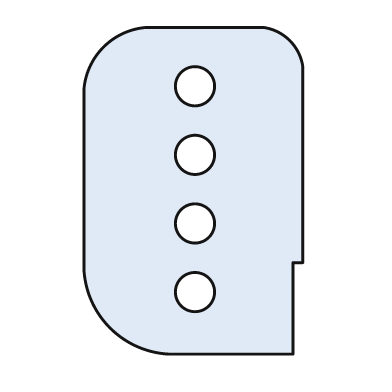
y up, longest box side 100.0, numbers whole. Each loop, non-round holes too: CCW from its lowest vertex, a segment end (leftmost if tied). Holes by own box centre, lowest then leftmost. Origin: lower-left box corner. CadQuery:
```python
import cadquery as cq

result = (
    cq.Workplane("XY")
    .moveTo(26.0, 0.0)
    .lineTo(64.0, 0.0)
    .lineTo(64.0, 28.0)
    .lineTo(67.0, 28.0)
    .lineTo(67.0, 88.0)
    .threePointArc((63.0, 96.0), (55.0, 100.0))
    .lineTo(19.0, 100.0)
    .threePointArc((6.0, 94.0), (0.0, 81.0))
    .lineTo(0.0, 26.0)
    .threePointArc((8.0, 8.0), (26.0, 0.0))
    .close()
    .moveTo(34.0, 19.0)
    .circle(6.0)
    .moveTo(34.0, 40.0)
    .circle(6.0)
    .moveTo(34.0, 61.0)
    .circle(6.0)
    .moveTo(34.0, 82.0)
    .circle(6.0)
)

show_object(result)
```